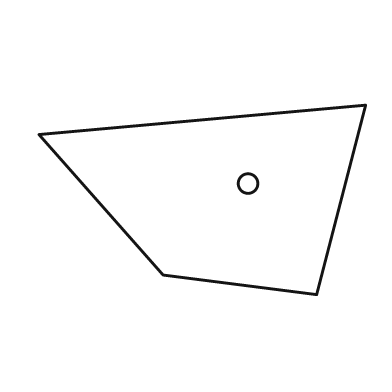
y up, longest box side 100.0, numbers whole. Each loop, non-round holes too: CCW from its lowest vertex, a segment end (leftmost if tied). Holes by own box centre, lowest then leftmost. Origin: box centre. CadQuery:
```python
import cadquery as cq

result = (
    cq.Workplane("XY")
    .moveTo(35.0, -29.0)
    .lineTo(50.0, 29.0)
    .lineTo(-50.0, 20.0)
    .lineTo(-12.0, -23.0)
    .close()
    .moveTo(14.0, 5.0)
    .circle(3.0)
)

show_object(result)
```